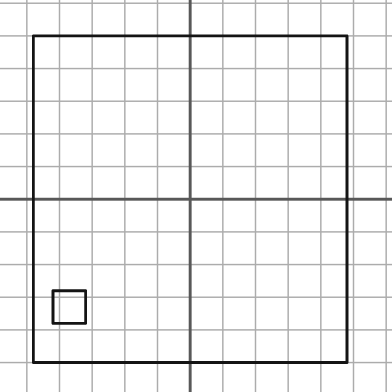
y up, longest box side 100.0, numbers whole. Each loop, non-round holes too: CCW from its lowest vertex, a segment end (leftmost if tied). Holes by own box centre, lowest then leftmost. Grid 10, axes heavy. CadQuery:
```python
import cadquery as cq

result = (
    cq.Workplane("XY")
    .moveTo(-48.0, -50.0)
    .lineTo(48.0, -50.0)
    .lineTo(48.0, 50.0)
    .lineTo(-48.0, 50.0)
    .close()
    .moveTo(-42.0, -38.0)
    .lineTo(-32.0, -38.0)
    .lineTo(-32.0, -28.0)
    .lineTo(-42.0, -28.0)
    .close()
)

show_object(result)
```